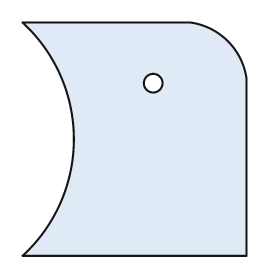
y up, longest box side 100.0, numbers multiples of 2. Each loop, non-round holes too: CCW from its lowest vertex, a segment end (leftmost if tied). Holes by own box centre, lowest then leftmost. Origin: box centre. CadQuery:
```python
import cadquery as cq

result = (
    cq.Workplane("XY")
    .moveTo(-48.0, -50.0)
    .lineTo(48.0, -50.0)
    .lineTo(48.0, 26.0)
    .threePointArc((40.0, 42.0), (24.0, 50.0))
    .lineTo(-48.0, 50.0)
    .threePointArc((-26.0, 0.0), (-48.0, -50.0))
    .close()
    .moveTo(8.0, 24.0)
    .circle(4.0)
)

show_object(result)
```